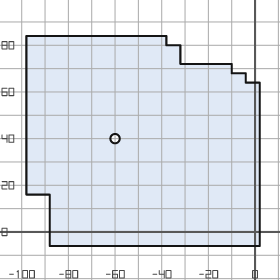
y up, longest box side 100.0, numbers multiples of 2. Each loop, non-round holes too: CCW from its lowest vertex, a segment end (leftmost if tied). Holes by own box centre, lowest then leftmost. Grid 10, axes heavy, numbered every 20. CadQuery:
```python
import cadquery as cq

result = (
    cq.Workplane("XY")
    .moveTo(-88.0, -6.0)
    .lineTo(2.0, -6.0)
    .lineTo(2.0, 64.0)
    .lineTo(-4.0, 64.0)
    .lineTo(-4.0, 68.0)
    .lineTo(-10.0, 68.0)
    .lineTo(-10.0, 72.0)
    .lineTo(-32.0, 72.0)
    .lineTo(-32.0, 80.0)
    .lineTo(-38.0, 80.0)
    .lineTo(-38.0, 84.0)
    .lineTo(-98.0, 84.0)
    .lineTo(-98.0, 16.0)
    .lineTo(-88.0, 16.0)
    .close()
    .moveTo(-60.0, 40.0)
    .circle(2.0)
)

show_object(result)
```